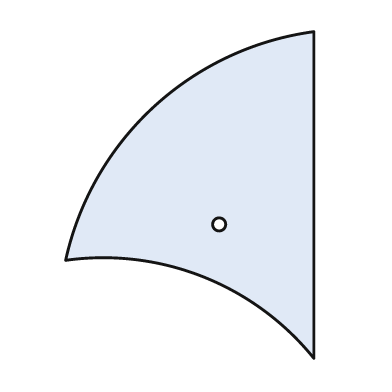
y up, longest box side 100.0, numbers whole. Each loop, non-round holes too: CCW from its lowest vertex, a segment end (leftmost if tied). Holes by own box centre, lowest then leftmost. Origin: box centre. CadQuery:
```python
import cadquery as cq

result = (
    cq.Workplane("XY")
    .moveTo(38.0, -50.0)
    .lineTo(38.0, 50.0)
    .threePointArc((-11.0, 27.0), (-38.0, -20.0))
    .threePointArc((4.0, -25.0), (38.0, -50.0))
    .close()
    .moveTo(9.0, -9.0)
    .circle(2.0)
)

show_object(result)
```